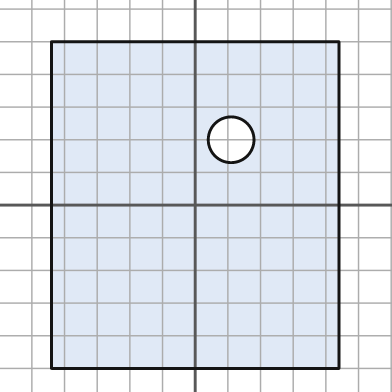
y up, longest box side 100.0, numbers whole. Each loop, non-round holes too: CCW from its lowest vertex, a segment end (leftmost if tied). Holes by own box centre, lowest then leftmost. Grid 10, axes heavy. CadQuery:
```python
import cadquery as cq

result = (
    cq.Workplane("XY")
    .moveTo(-44.0, -50.0)
    .lineTo(44.0, -50.0)
    .lineTo(44.0, 50.0)
    .lineTo(-44.0, 50.0)
    .close()
    .moveTo(11.0, 20.0)
    .circle(7.0)
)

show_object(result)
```